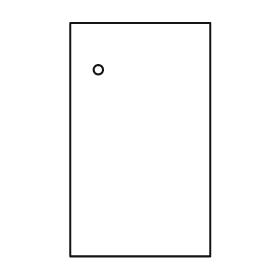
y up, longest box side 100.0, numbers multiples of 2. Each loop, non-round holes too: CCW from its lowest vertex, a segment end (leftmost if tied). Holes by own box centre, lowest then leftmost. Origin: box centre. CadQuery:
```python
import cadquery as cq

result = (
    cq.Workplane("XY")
    .moveTo(-30.0, -50.0)
    .lineTo(30.0, -50.0)
    .lineTo(30.0, 50.0)
    .lineTo(-30.0, 50.0)
    .close()
    .moveTo(-18.0, 30.0)
    .circle(2.0)
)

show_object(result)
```